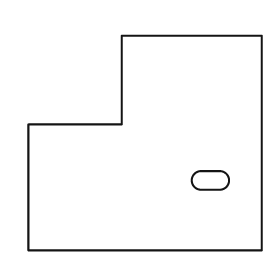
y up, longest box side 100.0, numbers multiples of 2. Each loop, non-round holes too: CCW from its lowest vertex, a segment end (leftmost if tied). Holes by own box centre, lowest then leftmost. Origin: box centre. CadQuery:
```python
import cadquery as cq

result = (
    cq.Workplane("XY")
    .moveTo(-50.0, -46.0)
    .lineTo(50.0, -46.0)
    .lineTo(50.0, 46.0)
    .lineTo(-10.0, 46.0)
    .lineTo(-10.0, 8.0)
    .lineTo(-50.0, 8.0)
    .close()
    .moveTo(24.0, -20.0)
    .lineTo(32.0, -20.0)
    .threePointArc((36.0, -16.0), (32.0, -12.0))
    .lineTo(24.0, -12.0)
    .threePointArc((20.0, -16.0), (24.0, -20.0))
    .close()
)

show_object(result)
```